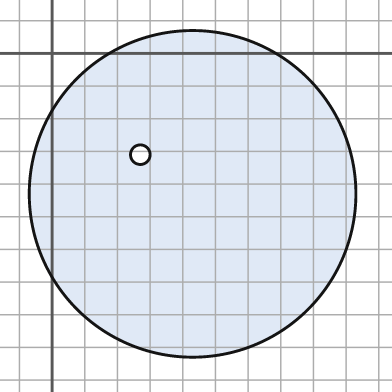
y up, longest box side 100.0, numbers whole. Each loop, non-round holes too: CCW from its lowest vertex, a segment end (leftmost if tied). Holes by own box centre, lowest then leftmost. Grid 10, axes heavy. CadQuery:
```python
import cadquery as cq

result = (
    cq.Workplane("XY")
    .moveTo(43.0, -43.0)
    .circle(50.0)
    .moveTo(27.0, -31.0)
    .circle(3.0)
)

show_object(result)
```